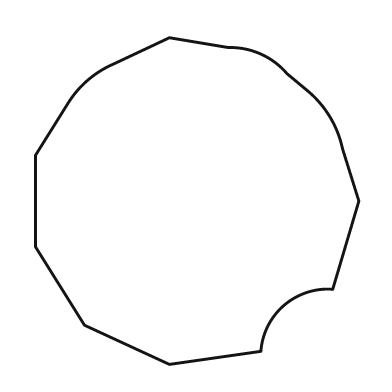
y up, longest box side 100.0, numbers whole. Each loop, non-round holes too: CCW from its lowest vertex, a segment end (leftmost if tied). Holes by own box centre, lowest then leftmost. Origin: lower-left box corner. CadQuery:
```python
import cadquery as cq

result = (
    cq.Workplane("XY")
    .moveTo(41.0, 0.0)
    .lineTo(69.0, 4.0)
    .threePointArc((76.0, 18.0), (91.0, 23.0))
    .lineTo(99.0, 50.0)
    .lineTo(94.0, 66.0)
    .threePointArc((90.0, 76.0), (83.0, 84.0))
    .lineTo(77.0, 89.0)
    .threePointArc((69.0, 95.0), (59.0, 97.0))
    .lineTo(41.0, 100.0)
    .lineTo(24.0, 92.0)
    .threePointArc((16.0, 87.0), (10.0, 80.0))
    .lineTo(0.0, 64.0)
    .lineTo(0.0, 36.0)
    .lineTo(15.0, 12.0)
    .close()
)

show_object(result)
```